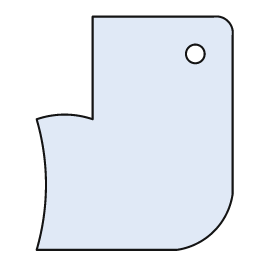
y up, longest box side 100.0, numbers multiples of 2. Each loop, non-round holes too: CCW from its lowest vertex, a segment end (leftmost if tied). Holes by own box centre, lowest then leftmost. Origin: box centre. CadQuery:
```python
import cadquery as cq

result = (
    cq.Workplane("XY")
    .moveTo(-42.0, -50.0)
    .lineTo(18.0, -50.0)
    .threePointArc((34.0, -42.0), (42.0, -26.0))
    .lineTo(42.0, 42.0)
    .threePointArc((40.0, 48.0), (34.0, 50.0))
    .lineTo(-18.0, 50.0)
    .lineTo(-18.0, 6.0)
    .threePointArc((-30.0, 8.0), (-42.0, 6.0))
    .threePointArc((-38.0, -22.0), (-42.0, -50.0))
    .close()
    .moveTo(26.0, 34.0)
    .circle(4.0)
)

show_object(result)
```